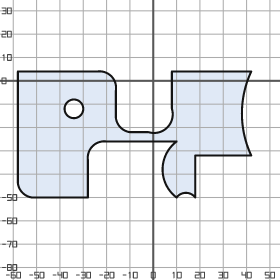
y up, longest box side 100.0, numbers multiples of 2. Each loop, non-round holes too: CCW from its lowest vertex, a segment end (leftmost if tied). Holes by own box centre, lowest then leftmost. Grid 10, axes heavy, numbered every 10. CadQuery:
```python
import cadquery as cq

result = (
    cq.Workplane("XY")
    .moveTo(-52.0, -50.0)
    .lineTo(-28.0, -50.0)
    .lineTo(-28.0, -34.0)
    .threePointArc((-26.0, -28.0), (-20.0, -26.0))
    .lineTo(10.0, -26.0)
    .threePointArc((4.0, -38.0), (10.0, -50.0))
    .threePointArc((14.0, -48.0), (18.0, -50.0))
    .lineTo(18.0, -32.0)
    .lineTo(42.0, -32.0)
    .threePointArc((38.0, -14.0), (42.0, 4.0))
    .lineTo(8.0, 4.0)
    .lineTo(8.0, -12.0)
    .threePointArc((6.0, -20.0), (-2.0, -22.0))
    .lineTo(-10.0, -22.0)
    .threePointArc((-14.0, -20.0), (-16.0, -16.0))
    .lineTo(-16.0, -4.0)
    .threePointArc((-18.0, 2.0), (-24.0, 4.0))
    .lineTo(-58.0, 4.0)
    .lineTo(-58.0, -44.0)
    .threePointArc((-56.0, -48.0), (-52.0, -50.0))
    .close()
    .moveTo(-34.0, -12.0)
    .circle(4.0)
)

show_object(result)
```